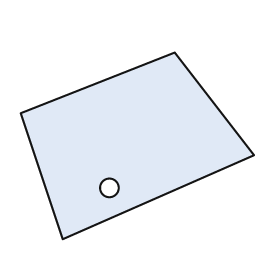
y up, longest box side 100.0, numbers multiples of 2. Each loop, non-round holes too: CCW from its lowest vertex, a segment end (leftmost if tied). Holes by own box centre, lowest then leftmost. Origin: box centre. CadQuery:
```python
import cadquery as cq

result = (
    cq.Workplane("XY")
    .moveTo(-32.0, -40.0)
    .lineTo(50.0, -4.0)
    .lineTo(16.0, 40.0)
    .lineTo(-50.0, 14.0)
    .close()
    .moveTo(-12.0, -18.0)
    .circle(4.0)
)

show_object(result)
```